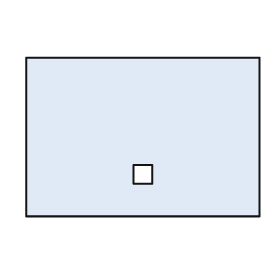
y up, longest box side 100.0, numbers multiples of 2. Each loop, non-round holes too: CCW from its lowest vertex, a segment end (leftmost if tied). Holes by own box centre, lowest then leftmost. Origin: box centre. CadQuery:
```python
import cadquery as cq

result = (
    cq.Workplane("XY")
    .moveTo(-50.0, -34.0)
    .lineTo(50.0, -34.0)
    .lineTo(50.0, 34.0)
    .lineTo(-50.0, 34.0)
    .close()
    .moveTo(-4.0, -20.0)
    .lineTo(4.0, -20.0)
    .lineTo(4.0, -12.0)
    .lineTo(-4.0, -12.0)
    .close()
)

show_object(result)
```